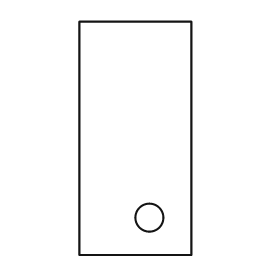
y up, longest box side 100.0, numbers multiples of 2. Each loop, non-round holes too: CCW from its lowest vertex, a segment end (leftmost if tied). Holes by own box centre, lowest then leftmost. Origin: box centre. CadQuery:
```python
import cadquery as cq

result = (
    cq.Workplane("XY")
    .moveTo(-24.0, -50.0)
    .lineTo(24.0, -50.0)
    .lineTo(24.0, 50.0)
    .lineTo(-24.0, 50.0)
    .close()
    .moveTo(6.0, -34.0)
    .circle(6.0)
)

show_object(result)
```